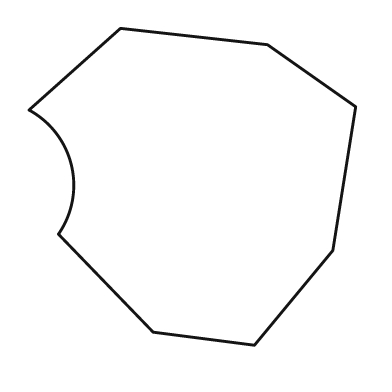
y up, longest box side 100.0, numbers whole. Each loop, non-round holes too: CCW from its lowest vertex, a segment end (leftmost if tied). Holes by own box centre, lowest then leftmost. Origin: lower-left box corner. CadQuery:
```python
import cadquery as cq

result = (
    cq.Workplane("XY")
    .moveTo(69.0, 0.0)
    .lineTo(93.0, 29.0)
    .lineTo(100.0, 73.0)
    .lineTo(73.0, 92.0)
    .lineTo(28.0, 97.0)
    .lineTo(0.0, 72.0)
    .threePointArc((13.0, 55.0), (9.0, 34.0))
    .lineTo(38.0, 4.0)
    .close()
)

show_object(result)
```